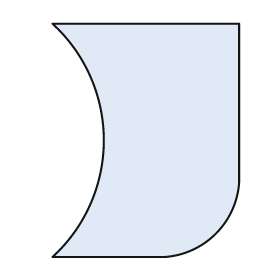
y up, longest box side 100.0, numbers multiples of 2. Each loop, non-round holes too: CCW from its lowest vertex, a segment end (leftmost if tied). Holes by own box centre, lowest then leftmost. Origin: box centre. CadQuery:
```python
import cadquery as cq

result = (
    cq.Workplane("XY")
    .moveTo(-40.0, -50.0)
    .lineTo(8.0, -50.0)
    .threePointArc((30.0, -40.0), (40.0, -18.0))
    .lineTo(40.0, 50.0)
    .lineTo(-40.0, 50.0)
    .threePointArc((-18.0, 0.0), (-40.0, -50.0))
    .close()
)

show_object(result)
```